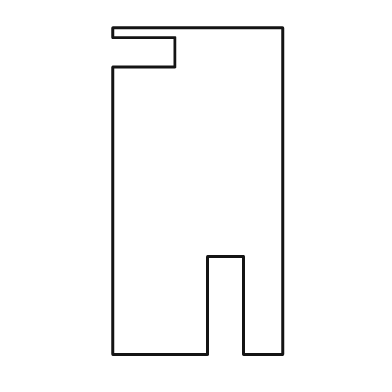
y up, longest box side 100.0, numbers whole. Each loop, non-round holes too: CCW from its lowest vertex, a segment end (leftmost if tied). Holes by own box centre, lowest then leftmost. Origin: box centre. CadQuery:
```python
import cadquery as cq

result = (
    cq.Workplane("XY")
    .moveTo(-26.0, -50.0)
    .lineTo(3.0, -50.0)
    .lineTo(3.0, -20.0)
    .lineTo(14.0, -20.0)
    .lineTo(14.0, -50.0)
    .lineTo(26.0, -50.0)
    .lineTo(26.0, 50.0)
    .lineTo(-26.0, 50.0)
    .lineTo(-26.0, 47.0)
    .lineTo(-7.0, 47.0)
    .lineTo(-7.0, 38.0)
    .lineTo(-26.0, 38.0)
    .close()
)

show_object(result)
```